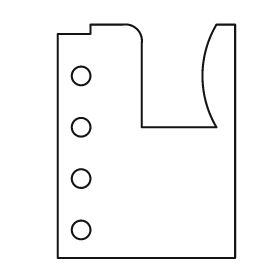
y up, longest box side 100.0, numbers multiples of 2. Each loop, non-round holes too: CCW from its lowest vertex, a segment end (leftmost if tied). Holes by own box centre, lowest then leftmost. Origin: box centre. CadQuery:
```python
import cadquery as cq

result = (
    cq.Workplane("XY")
    .moveTo(-38.0, -50.0)
    .lineTo(38.0, -50.0)
    .lineTo(38.0, 50.0)
    .lineTo(30.0, 50.0)
    .threePointArc((24.0, 28.0), (30.0, 6.0))
    .lineTo(-2.0, 6.0)
    .lineTo(-2.0, 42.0)
    .threePointArc((-4.0, 48.0), (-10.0, 50.0))
    .lineTo(-24.0, 50.0)
    .lineTo(-24.0, 46.0)
    .lineTo(-38.0, 46.0)
    .close()
    .moveTo(-28.0, -38.0)
    .circle(4.0)
    .moveTo(-28.0, -16.0)
    .circle(4.0)
    .moveTo(-28.0, 6.0)
    .circle(4.0)
    .moveTo(-28.0, 28.0)
    .circle(4.0)
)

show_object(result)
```